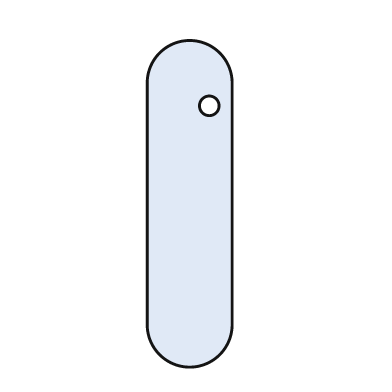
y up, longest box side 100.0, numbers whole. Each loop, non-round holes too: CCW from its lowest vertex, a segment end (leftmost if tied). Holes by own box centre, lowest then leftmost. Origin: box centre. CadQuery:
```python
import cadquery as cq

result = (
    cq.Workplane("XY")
    .moveTo(-13.0, -37.0)
    .threePointArc((0.0, -50.0), (13.0, -37.0))
    .lineTo(13.0, 37.0)
    .threePointArc((0.0, 50.0), (-13.0, 37.0))
    .close()
    .moveTo(6.0, 30.0)
    .circle(3.0)
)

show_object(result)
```